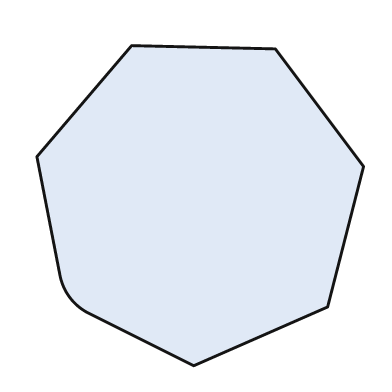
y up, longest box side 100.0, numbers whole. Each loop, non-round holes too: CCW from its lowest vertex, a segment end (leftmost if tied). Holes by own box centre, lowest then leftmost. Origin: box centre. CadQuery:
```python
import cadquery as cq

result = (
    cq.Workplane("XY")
    .moveTo(-2.0, -49.0)
    .lineTo(39.0, -31.0)
    .lineTo(50.0, 12.0)
    .lineTo(23.0, 48.0)
    .lineTo(-21.0, 49.0)
    .lineTo(-50.0, 15.0)
    .lineTo(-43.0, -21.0)
    .threePointArc((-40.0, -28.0), (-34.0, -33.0))
    .close()
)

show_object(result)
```